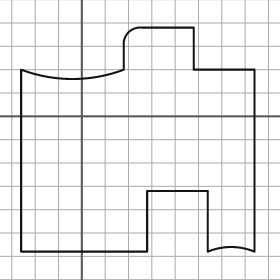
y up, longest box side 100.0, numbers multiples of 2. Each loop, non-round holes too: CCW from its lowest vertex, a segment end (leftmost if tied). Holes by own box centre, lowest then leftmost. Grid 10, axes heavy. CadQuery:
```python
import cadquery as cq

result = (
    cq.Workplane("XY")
    .moveTo(-26.0, -58.0)
    .lineTo(28.0, -58.0)
    .lineTo(28.0, -32.0)
    .lineTo(54.0, -32.0)
    .lineTo(54.0, -58.0)
    .threePointArc((64.0, -56.0), (74.0, -58.0))
    .lineTo(74.0, 20.0)
    .lineTo(48.0, 20.0)
    .lineTo(48.0, 38.0)
    .lineTo(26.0, 38.0)
    .threePointArc((20.0, 36.0), (18.0, 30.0))
    .lineTo(18.0, 20.0)
    .threePointArc((-4.0, 16.0), (-26.0, 20.0))
    .close()
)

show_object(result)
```